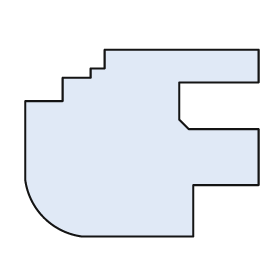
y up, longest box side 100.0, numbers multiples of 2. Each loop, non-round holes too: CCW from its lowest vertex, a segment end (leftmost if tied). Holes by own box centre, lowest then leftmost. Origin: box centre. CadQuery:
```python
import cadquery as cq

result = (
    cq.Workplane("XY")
    .moveTo(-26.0, -40.0)
    .lineTo(22.0, -40.0)
    .lineTo(22.0, -18.0)
    .lineTo(50.0, -18.0)
    .lineTo(50.0, 6.0)
    .lineTo(20.0, 6.0)
    .lineTo(16.0, 10.0)
    .lineTo(16.0, 26.0)
    .lineTo(50.0, 26.0)
    .lineTo(50.0, 40.0)
    .lineTo(-16.0, 40.0)
    .lineTo(-16.0, 32.0)
    .lineTo(-22.0, 32.0)
    .lineTo(-22.0, 28.0)
    .lineTo(-34.0, 28.0)
    .lineTo(-34.0, 18.0)
    .lineTo(-50.0, 18.0)
    .lineTo(-50.0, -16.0)
    .threePointArc((-42.0, -32.0), (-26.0, -40.0))
    .close()
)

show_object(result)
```